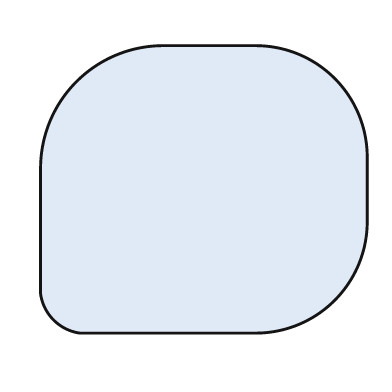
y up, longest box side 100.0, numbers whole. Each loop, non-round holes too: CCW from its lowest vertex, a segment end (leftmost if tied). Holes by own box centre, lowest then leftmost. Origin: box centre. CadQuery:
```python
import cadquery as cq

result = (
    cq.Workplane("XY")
    .moveTo(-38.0, -44.0)
    .lineTo(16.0, -44.0)
    .threePointArc((40.0, -34.0), (50.0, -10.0))
    .lineTo(50.0, 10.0)
    .threePointArc((40.0, 34.0), (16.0, 44.0))
    .lineTo(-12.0, 44.0)
    .threePointArc((-39.0, 33.0), (-50.0, 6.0))
    .lineTo(-50.0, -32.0)
    .threePointArc((-46.0, -40.0), (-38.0, -44.0))
    .close()
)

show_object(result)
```